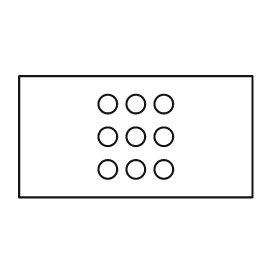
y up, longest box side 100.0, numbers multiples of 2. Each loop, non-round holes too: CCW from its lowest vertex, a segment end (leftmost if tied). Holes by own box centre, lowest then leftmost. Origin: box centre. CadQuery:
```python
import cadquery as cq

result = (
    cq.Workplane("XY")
    .moveTo(-50.0, -26.0)
    .lineTo(50.0, -26.0)
    .lineTo(50.0, 26.0)
    .lineTo(-50.0, 26.0)
    .close()
    .moveTo(-12.0, -14.0)
    .circle(4.0)
    .moveTo(0.0, -14.0)
    .circle(4.0)
    .moveTo(12.0, -14.0)
    .circle(4.0)
    .moveTo(-12.0, 0.0)
    .circle(4.0)
    .moveTo(0.0, 0.0)
    .circle(4.0)
    .moveTo(12.0, 0.0)
    .circle(4.0)
    .moveTo(-12.0, 14.0)
    .circle(4.0)
    .moveTo(0.0, 14.0)
    .circle(4.0)
    .moveTo(12.0, 14.0)
    .circle(4.0)
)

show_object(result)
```